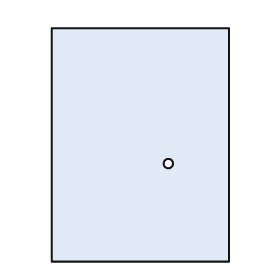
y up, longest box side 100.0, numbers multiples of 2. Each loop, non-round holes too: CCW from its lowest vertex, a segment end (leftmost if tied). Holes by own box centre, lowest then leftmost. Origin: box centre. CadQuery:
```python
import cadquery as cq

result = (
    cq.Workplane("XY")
    .moveTo(-38.0, -50.0)
    .lineTo(38.0, -50.0)
    .lineTo(38.0, 50.0)
    .lineTo(-38.0, 50.0)
    .close()
    .moveTo(12.0, -8.0)
    .circle(2.0)
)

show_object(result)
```